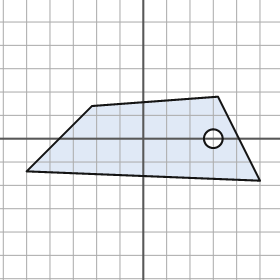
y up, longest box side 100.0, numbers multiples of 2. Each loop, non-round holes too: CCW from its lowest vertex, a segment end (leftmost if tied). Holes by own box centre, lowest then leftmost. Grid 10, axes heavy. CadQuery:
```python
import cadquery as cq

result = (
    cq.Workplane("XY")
    .moveTo(50.0, -18.0)
    .lineTo(32.0, 18.0)
    .lineTo(-22.0, 14.0)
    .lineTo(-50.0, -14.0)
    .close()
    .moveTo(30.0, 0.0)
    .circle(4.0)
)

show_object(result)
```